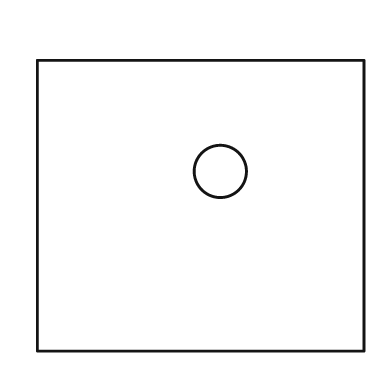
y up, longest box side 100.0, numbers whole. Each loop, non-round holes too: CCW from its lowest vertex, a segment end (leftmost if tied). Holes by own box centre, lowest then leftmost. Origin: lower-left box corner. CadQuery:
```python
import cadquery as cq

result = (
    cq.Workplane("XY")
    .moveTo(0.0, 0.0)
    .lineTo(100.0, 0.0)
    .lineTo(100.0, 89.0)
    .lineTo(0.0, 89.0)
    .close()
    .moveTo(56.0, 55.0)
    .circle(8.0)
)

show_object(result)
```